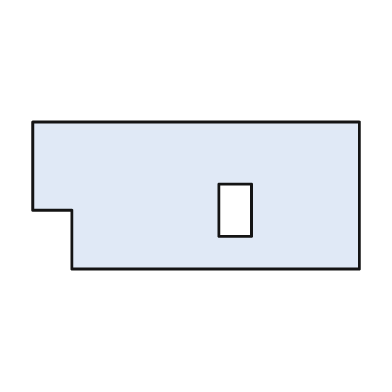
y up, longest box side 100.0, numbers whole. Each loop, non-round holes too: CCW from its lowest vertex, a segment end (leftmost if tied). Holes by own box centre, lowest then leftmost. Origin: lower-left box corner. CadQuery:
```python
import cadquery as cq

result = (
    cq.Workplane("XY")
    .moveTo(12.0, 0.0)
    .lineTo(100.0, 0.0)
    .lineTo(100.0, 45.0)
    .lineTo(0.0, 45.0)
    .lineTo(0.0, 18.0)
    .lineTo(12.0, 18.0)
    .close()
    .moveTo(57.0, 10.0)
    .lineTo(67.0, 10.0)
    .lineTo(67.0, 26.0)
    .lineTo(57.0, 26.0)
    .close()
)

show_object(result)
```